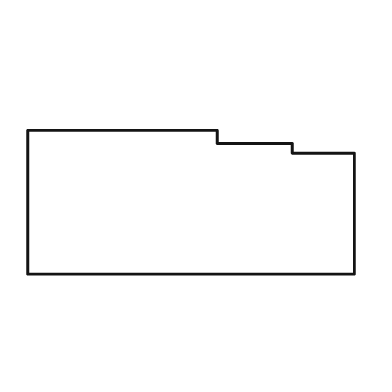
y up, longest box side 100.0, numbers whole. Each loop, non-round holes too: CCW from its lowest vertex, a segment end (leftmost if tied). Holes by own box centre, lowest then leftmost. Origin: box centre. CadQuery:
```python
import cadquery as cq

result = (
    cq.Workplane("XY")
    .moveTo(-50.0, -22.0)
    .lineTo(50.0, -22.0)
    .lineTo(50.0, 15.0)
    .lineTo(31.0, 15.0)
    .lineTo(31.0, 18.0)
    .lineTo(8.0, 18.0)
    .lineTo(8.0, 22.0)
    .lineTo(-50.0, 22.0)
    .close()
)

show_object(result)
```